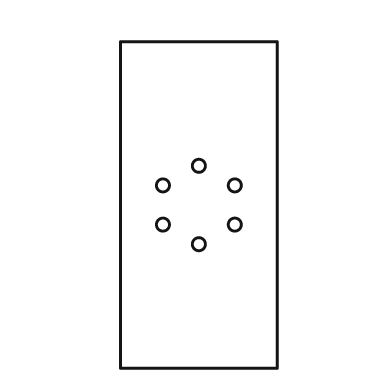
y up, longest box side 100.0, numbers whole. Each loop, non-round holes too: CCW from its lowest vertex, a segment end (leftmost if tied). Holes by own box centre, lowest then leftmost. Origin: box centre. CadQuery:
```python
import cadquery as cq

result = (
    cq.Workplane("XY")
    .moveTo(-24.0, -50.0)
    .lineTo(24.0, -50.0)
    .lineTo(24.0, 50.0)
    .lineTo(-24.0, 50.0)
    .close()
    .moveTo(0.0, -12.0)
    .circle(2.0)
    .moveTo(-11.0, -6.0)
    .circle(2.0)
    .moveTo(11.0, -6.0)
    .circle(2.0)
    .moveTo(-11.0, 6.0)
    .circle(2.0)
    .moveTo(11.0, 6.0)
    .circle(2.0)
    .moveTo(0.0, 12.0)
    .circle(2.0)
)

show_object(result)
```